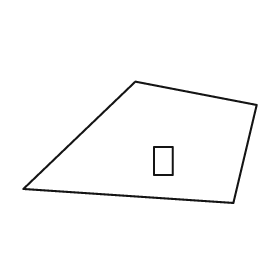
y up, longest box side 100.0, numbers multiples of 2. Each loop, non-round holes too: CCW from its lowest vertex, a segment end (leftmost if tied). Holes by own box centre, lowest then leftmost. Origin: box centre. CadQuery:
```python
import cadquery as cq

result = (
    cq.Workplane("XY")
    .moveTo(40.0, -26.0)
    .lineTo(50.0, 16.0)
    .lineTo(-2.0, 26.0)
    .lineTo(-50.0, -20.0)
    .close()
    .moveTo(6.0, -14.0)
    .lineTo(14.0, -14.0)
    .lineTo(14.0, -2.0)
    .lineTo(6.0, -2.0)
    .close()
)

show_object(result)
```